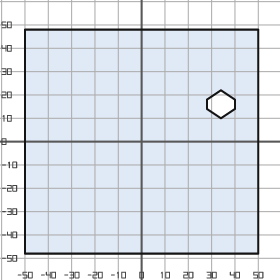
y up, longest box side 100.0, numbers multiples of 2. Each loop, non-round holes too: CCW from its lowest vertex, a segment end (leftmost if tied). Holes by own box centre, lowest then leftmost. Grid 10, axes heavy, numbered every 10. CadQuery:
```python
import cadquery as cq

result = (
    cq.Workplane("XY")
    .moveTo(-50.0, -48.0)
    .lineTo(50.0, -48.0)
    .lineTo(50.0, 48.0)
    .lineTo(-50.0, 48.0)
    .close()
    .moveTo(34.0, 10.0)
    .lineTo(40.0, 14.0)
    .lineTo(40.0, 18.0)
    .lineTo(34.0, 22.0)
    .lineTo(28.0, 18.0)
    .lineTo(28.0, 14.0)
    .close()
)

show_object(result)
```